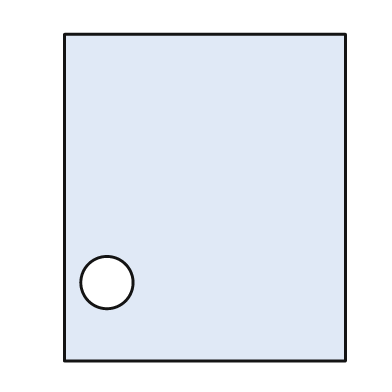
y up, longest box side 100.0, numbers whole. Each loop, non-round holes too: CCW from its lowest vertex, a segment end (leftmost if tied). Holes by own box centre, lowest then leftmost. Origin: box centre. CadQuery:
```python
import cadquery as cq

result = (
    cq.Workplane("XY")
    .moveTo(-43.0, -50.0)
    .lineTo(43.0, -50.0)
    .lineTo(43.0, 50.0)
    .lineTo(-43.0, 50.0)
    .close()
    .moveTo(-30.0, -26.0)
    .circle(8.0)
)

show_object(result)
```